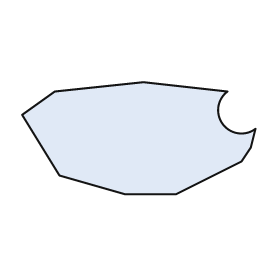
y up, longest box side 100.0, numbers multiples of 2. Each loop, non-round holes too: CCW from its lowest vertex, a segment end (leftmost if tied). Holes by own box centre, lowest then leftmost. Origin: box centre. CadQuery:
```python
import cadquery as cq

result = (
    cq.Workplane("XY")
    .moveTo(-6.0, -24.0)
    .lineTo(16.0, -24.0)
    .lineTo(44.0, -10.0)
    .lineTo(48.0, -4.0)
    .lineTo(50.0, 4.0)
    .threePointArc((36.0, 6.0), (38.0, 20.0))
    .lineTo(2.0, 24.0)
    .lineTo(-36.0, 20.0)
    .lineTo(-50.0, 10.0)
    .lineTo(-34.0, -16.0)
    .close()
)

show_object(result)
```